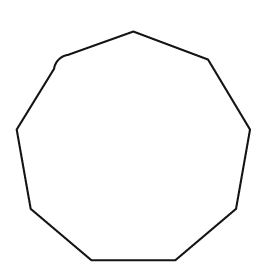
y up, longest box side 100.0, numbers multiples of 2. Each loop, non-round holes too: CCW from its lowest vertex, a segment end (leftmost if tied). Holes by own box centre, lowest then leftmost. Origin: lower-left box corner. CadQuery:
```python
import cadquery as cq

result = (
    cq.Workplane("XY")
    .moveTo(32.0, 0.0)
    .lineTo(68.0, 0.0)
    .lineTo(94.0, 22.0)
    .lineTo(100.0, 56.0)
    .lineTo(82.0, 86.0)
    .lineTo(50.0, 98.0)
    .lineTo(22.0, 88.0)
    .threePointArc((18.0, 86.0), (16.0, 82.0))
    .lineTo(0.0, 56.0)
    .lineTo(6.0, 22.0)
    .close()
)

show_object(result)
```